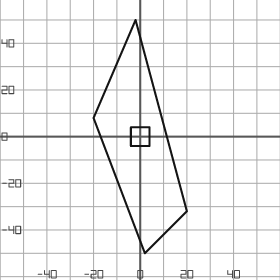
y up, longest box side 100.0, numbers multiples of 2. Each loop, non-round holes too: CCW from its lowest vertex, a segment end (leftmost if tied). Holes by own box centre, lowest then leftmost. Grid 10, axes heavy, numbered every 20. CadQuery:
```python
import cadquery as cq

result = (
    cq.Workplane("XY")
    .moveTo(2.0, -50.0)
    .lineTo(20.0, -32.0)
    .lineTo(-2.0, 50.0)
    .lineTo(-20.0, 8.0)
    .close()
    .moveTo(-4.0, -4.0)
    .lineTo(4.0, -4.0)
    .lineTo(4.0, 4.0)
    .lineTo(-4.0, 4.0)
    .close()
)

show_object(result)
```